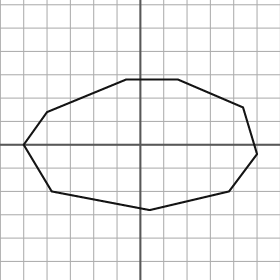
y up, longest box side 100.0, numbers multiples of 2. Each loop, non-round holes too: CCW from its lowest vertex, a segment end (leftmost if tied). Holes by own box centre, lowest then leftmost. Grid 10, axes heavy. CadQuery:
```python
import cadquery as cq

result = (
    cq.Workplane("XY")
    .moveTo(4.0, -28.0)
    .lineTo(38.0, -20.0)
    .lineTo(50.0, -4.0)
    .lineTo(44.0, 16.0)
    .lineTo(16.0, 28.0)
    .lineTo(-6.0, 28.0)
    .lineTo(-40.0, 14.0)
    .lineTo(-50.0, 0.0)
    .lineTo(-38.0, -20.0)
    .close()
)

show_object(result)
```